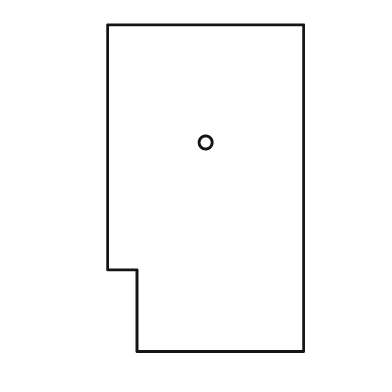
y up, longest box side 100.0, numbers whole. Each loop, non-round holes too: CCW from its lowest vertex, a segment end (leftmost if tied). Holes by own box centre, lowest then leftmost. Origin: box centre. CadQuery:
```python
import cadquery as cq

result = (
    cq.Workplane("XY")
    .moveTo(-21.0, -50.0)
    .lineTo(30.0, -50.0)
    .lineTo(30.0, 50.0)
    .lineTo(-30.0, 50.0)
    .lineTo(-30.0, -25.0)
    .lineTo(-21.0, -25.0)
    .close()
    .moveTo(0.0, 14.0)
    .circle(2.0)
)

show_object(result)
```